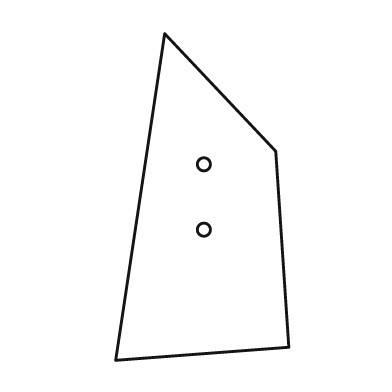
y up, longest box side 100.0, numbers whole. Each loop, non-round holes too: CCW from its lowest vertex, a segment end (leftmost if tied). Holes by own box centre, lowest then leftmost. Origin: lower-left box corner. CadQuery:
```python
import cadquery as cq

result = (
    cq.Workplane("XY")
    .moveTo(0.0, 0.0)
    .lineTo(53.0, 4.0)
    .lineTo(49.0, 64.0)
    .lineTo(15.0, 100.0)
    .close()
    .moveTo(27.0, 40.0)
    .circle(2.0)
    .moveTo(27.0, 60.0)
    .circle(2.0)
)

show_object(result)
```